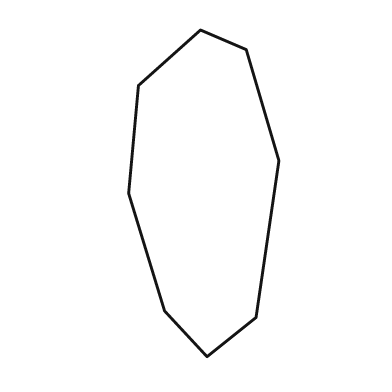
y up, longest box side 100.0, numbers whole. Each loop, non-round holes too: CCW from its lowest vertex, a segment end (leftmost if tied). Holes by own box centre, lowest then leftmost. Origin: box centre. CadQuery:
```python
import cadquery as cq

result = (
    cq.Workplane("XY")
    .moveTo(1.0, -50.0)
    .lineTo(16.0, -38.0)
    .lineTo(23.0, 10.0)
    .lineTo(13.0, 44.0)
    .lineTo(-1.0, 50.0)
    .lineTo(-20.0, 33.0)
    .lineTo(-23.0, 0.0)
    .lineTo(-12.0, -36.0)
    .close()
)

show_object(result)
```